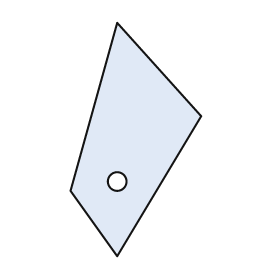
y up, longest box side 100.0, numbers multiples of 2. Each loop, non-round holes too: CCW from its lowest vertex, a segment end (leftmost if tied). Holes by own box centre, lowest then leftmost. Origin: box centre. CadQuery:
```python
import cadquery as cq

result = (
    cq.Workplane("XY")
    .moveTo(-8.0, -50.0)
    .lineTo(28.0, 10.0)
    .lineTo(-8.0, 50.0)
    .lineTo(-28.0, -22.0)
    .close()
    .moveTo(-8.0, -18.0)
    .circle(4.0)
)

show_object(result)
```